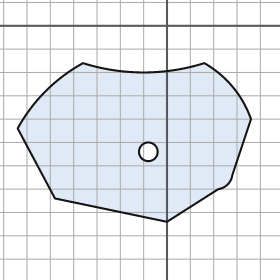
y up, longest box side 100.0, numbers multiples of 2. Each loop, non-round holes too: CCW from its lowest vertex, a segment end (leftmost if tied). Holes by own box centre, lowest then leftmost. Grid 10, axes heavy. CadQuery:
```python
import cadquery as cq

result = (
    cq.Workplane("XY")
    .moveTo(0.0, -84.0)
    .lineTo(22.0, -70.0)
    .threePointArc((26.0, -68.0), (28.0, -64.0))
    .lineTo(36.0, -40.0)
    .threePointArc((28.0, -26.0), (16.0, -16.0))
    .threePointArc((-10.0, -20.0), (-36.0, -16.0))
    .threePointArc((-52.0, -28.0), (-64.0, -44.0))
    .lineTo(-48.0, -74.0)
    .close()
    .moveTo(-8.0, -54.0)
    .circle(4.0)
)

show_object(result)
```